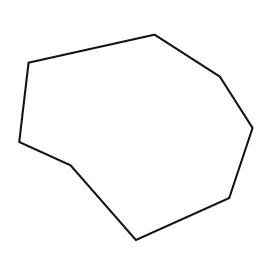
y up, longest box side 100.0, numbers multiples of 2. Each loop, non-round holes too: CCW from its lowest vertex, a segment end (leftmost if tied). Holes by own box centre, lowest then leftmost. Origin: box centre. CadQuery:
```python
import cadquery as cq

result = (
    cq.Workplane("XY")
    .moveTo(0.0, -44.0)
    .lineTo(40.0, -26.0)
    .lineTo(50.0, 4.0)
    .lineTo(36.0, 26.0)
    .lineTo(8.0, 44.0)
    .lineTo(-46.0, 32.0)
    .lineTo(-50.0, -2.0)
    .lineTo(-28.0, -12.0)
    .close()
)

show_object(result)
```